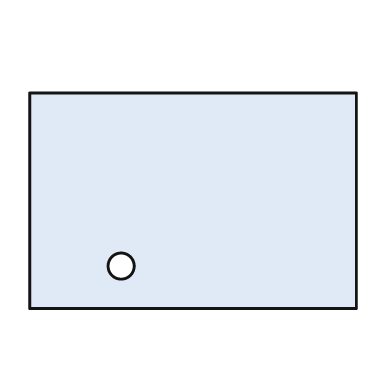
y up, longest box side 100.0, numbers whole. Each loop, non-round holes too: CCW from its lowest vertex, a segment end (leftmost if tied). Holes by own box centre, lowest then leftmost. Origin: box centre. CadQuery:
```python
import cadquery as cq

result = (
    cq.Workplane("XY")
    .moveTo(-50.0, -33.0)
    .lineTo(50.0, -33.0)
    .lineTo(50.0, 33.0)
    .lineTo(-50.0, 33.0)
    .close()
    .moveTo(-22.0, -20.0)
    .circle(4.0)
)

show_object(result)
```